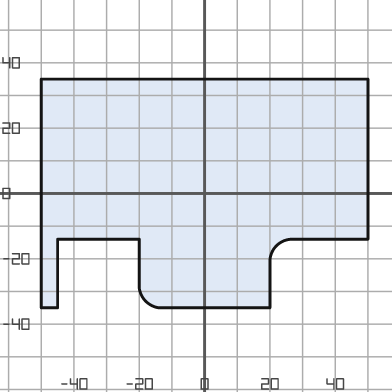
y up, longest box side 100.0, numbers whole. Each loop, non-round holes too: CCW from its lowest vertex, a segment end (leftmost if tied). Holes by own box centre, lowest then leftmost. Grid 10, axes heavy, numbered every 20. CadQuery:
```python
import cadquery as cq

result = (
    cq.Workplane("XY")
    .moveTo(-50.0, -35.0)
    .lineTo(-45.0, -35.0)
    .lineTo(-45.0, -14.0)
    .lineTo(-20.0, -14.0)
    .lineTo(-20.0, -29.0)
    .threePointArc((-18.0, -33.0), (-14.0, -35.0))
    .lineTo(20.0, -35.0)
    .lineTo(20.0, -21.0)
    .threePointArc((22.0, -16.0), (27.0, -14.0))
    .lineTo(50.0, -14.0)
    .lineTo(50.0, 35.0)
    .lineTo(-50.0, 35.0)
    .close()
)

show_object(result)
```